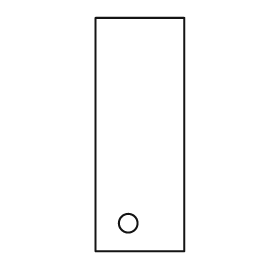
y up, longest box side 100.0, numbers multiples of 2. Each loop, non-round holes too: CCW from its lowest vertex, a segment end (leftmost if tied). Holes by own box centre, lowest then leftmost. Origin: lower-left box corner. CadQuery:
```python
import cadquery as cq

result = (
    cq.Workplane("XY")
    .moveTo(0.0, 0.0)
    .lineTo(38.0, 0.0)
    .lineTo(38.0, 100.0)
    .lineTo(0.0, 100.0)
    .close()
    .moveTo(14.0, 12.0)
    .circle(4.0)
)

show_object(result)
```